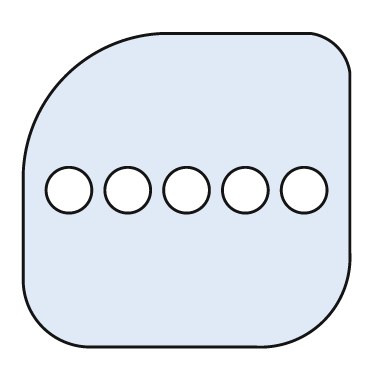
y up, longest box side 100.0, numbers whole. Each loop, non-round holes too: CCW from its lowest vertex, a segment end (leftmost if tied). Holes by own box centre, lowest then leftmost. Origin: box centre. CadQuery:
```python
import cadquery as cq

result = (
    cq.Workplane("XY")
    .moveTo(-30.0, -48.0)
    .lineTo(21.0, -48.0)
    .threePointArc((42.0, -40.0), (50.0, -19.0))
    .lineTo(50.0, 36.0)
    .threePointArc((46.0, 44.0), (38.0, 48.0))
    .lineTo(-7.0, 48.0)
    .threePointArc((-37.0, 35.0), (-50.0, 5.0))
    .lineTo(-50.0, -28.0)
    .threePointArc((-44.0, -42.0), (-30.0, -48.0))
    .close()
    .moveTo(-36.0, 0.0)
    .circle(7.0)
    .moveTo(-18.0, 0.0)
    .circle(7.0)
    .moveTo(0.0, 0.0)
    .circle(7.0)
    .moveTo(18.0, 0.0)
    .circle(7.0)
    .moveTo(36.0, 0.0)
    .circle(7.0)
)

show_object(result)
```